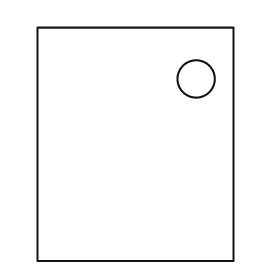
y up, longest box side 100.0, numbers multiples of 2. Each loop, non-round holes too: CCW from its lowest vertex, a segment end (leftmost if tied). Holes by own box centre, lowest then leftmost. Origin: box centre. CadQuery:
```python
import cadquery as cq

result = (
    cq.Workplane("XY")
    .moveTo(-42.0, -50.0)
    .lineTo(42.0, -50.0)
    .lineTo(42.0, 50.0)
    .lineTo(-42.0, 50.0)
    .close()
    .moveTo(26.0, 28.0)
    .circle(8.0)
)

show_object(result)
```